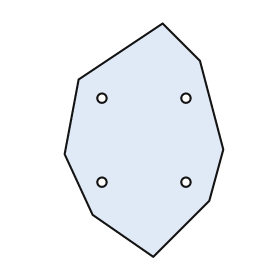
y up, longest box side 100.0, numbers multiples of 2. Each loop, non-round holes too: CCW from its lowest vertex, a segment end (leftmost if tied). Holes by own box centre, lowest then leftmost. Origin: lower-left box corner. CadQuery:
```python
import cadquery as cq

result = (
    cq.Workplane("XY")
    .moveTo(38.0, 0.0)
    .lineTo(62.0, 24.0)
    .lineTo(68.0, 46.0)
    .lineTo(58.0, 84.0)
    .lineTo(42.0, 100.0)
    .lineTo(6.0, 76.0)
    .lineTo(0.0, 44.0)
    .lineTo(12.0, 18.0)
    .close()
    .moveTo(16.0, 32.0)
    .circle(2.0)
    .moveTo(52.0, 32.0)
    .circle(2.0)
    .moveTo(16.0, 68.0)
    .circle(2.0)
    .moveTo(52.0, 68.0)
    .circle(2.0)
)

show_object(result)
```